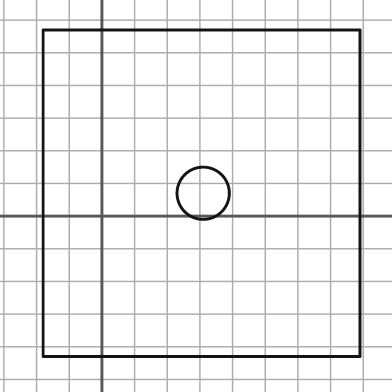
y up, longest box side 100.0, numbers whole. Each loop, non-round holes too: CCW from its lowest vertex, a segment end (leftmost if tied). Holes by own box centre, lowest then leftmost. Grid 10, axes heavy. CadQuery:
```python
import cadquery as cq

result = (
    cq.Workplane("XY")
    .moveTo(-18.0, -43.0)
    .lineTo(79.0, -43.0)
    .lineTo(79.0, 57.0)
    .lineTo(-18.0, 57.0)
    .close()
    .moveTo(31.0, 7.0)
    .circle(8.0)
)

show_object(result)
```